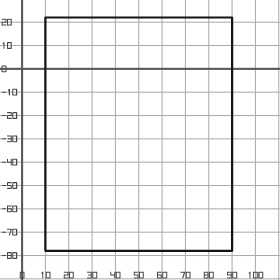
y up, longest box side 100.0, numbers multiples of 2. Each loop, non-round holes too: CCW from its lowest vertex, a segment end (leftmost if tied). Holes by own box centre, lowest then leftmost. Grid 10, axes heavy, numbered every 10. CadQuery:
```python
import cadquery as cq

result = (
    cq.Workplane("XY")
    .moveTo(10.0, -78.0)
    .lineTo(90.0, -78.0)
    .lineTo(90.0, 22.0)
    .lineTo(10.0, 22.0)
    .close()
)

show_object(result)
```